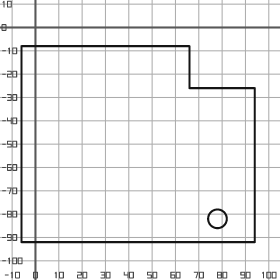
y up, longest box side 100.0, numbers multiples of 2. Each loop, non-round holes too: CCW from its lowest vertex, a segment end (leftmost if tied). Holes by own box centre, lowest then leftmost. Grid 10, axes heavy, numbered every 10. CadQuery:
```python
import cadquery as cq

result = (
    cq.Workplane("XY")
    .moveTo(-6.0, -92.0)
    .lineTo(94.0, -92.0)
    .lineTo(94.0, -26.0)
    .lineTo(66.0, -26.0)
    .lineTo(66.0, -8.0)
    .lineTo(-6.0, -8.0)
    .close()
    .moveTo(78.0, -82.0)
    .circle(4.0)
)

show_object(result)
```